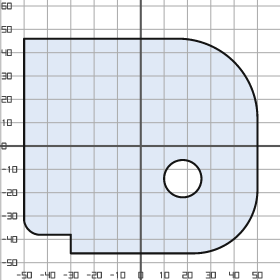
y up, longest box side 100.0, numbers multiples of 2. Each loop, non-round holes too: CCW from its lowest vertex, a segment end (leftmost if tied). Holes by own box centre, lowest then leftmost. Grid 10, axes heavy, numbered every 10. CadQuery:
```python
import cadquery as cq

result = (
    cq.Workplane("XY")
    .moveTo(-30.0, -46.0)
    .lineTo(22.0, -46.0)
    .threePointArc((42.0, -38.0), (50.0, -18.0))
    .lineTo(50.0, 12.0)
    .threePointArc((40.0, 36.0), (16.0, 46.0))
    .lineTo(-50.0, 46.0)
    .lineTo(-50.0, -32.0)
    .threePointArc((-48.0, -36.0), (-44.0, -38.0))
    .lineTo(-30.0, -38.0)
    .close()
    .moveTo(18.0, -14.0)
    .circle(8.0)
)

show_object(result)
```